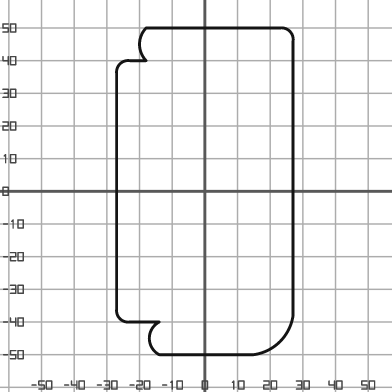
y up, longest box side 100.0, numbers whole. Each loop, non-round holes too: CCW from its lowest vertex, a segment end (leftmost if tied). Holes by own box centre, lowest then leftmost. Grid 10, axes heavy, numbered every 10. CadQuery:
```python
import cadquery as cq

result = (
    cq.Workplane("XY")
    .moveTo(-14.0, -50.0)
    .lineTo(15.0, -50.0)
    .threePointArc((23.0, -46.0), (27.0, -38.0))
    .lineTo(27.0, 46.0)
    .threePointArc((26.0, 49.0), (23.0, 50.0))
    .lineTo(-18.0, 50.0)
    .threePointArc((-20.0, 45.0), (-18.0, 40.0))
    .lineTo(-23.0, 40.0)
    .threePointArc((-26.0, 39.0), (-27.0, 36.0))
    .lineTo(-27.0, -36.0)
    .threePointArc((-26.0, -39.0), (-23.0, -40.0))
    .lineTo(-14.0, -40.0)
    .threePointArc((-17.0, -45.0), (-14.0, -50.0))
    .close()
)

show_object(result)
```